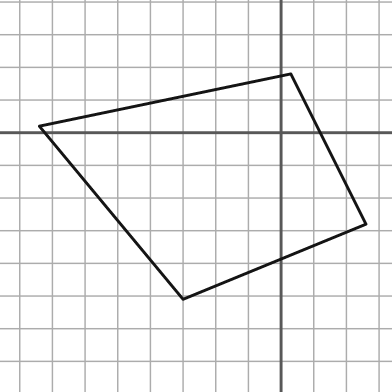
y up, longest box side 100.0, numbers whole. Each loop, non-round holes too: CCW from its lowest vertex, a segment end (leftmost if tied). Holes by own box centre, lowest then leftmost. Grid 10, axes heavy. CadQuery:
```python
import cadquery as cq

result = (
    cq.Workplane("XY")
    .moveTo(-30.0, -51.0)
    .lineTo(26.0, -28.0)
    .lineTo(3.0, 18.0)
    .lineTo(-74.0, 2.0)
    .close()
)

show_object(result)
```